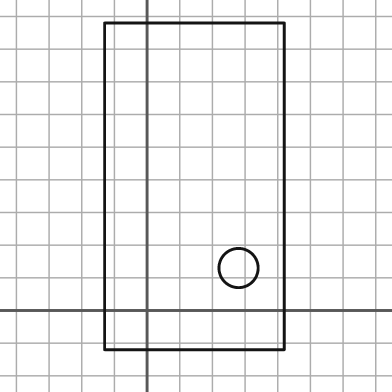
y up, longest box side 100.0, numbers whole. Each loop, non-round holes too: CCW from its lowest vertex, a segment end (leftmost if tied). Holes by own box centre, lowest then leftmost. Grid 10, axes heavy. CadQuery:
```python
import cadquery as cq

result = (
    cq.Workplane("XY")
    .moveTo(-13.0, -12.0)
    .lineTo(42.0, -12.0)
    .lineTo(42.0, 88.0)
    .lineTo(-13.0, 88.0)
    .close()
    .moveTo(28.0, 13.0)
    .circle(6.0)
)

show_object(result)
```